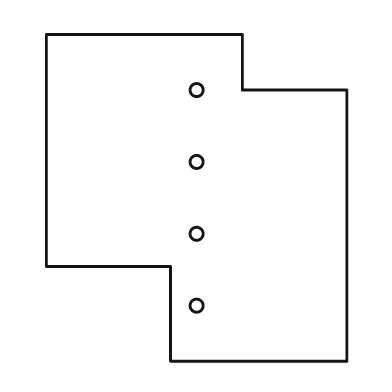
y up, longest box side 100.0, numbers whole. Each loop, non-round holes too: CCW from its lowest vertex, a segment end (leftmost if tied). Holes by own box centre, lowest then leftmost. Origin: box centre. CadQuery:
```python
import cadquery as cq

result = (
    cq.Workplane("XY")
    .moveTo(-8.0, -50.0)
    .lineTo(46.0, -50.0)
    .lineTo(46.0, 33.0)
    .lineTo(14.0, 33.0)
    .lineTo(14.0, 50.0)
    .lineTo(-46.0, 50.0)
    .lineTo(-46.0, -21.0)
    .lineTo(-8.0, -21.0)
    .close()
    .moveTo(0.0, -33.0)
    .circle(2.0)
    .moveTo(0.0, -11.0)
    .circle(2.0)
    .moveTo(0.0, 11.0)
    .circle(2.0)
    .moveTo(0.0, 33.0)
    .circle(2.0)
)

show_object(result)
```